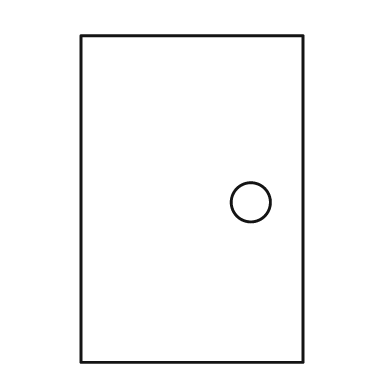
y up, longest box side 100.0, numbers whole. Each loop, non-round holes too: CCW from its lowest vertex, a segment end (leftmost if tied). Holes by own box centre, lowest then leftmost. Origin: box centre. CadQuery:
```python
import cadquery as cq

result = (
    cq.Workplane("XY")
    .moveTo(-34.0, -50.0)
    .lineTo(34.0, -50.0)
    .lineTo(34.0, 50.0)
    .lineTo(-34.0, 50.0)
    .close()
    .moveTo(18.0, -1.0)
    .circle(6.0)
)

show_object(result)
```